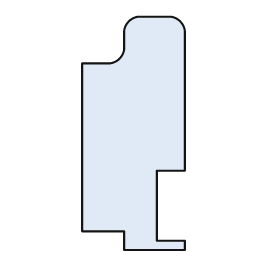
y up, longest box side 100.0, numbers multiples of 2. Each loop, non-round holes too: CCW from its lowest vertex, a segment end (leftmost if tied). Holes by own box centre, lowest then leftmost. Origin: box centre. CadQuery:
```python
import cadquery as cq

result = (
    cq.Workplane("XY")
    .moveTo(-4.0, -50.0)
    .lineTo(22.0, -50.0)
    .lineTo(22.0, -46.0)
    .lineTo(10.0, -46.0)
    .lineTo(10.0, -16.0)
    .lineTo(22.0, -16.0)
    .lineTo(22.0, 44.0)
    .threePointArc((20.0, 48.0), (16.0, 50.0))
    .lineTo(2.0, 50.0)
    .threePointArc((-2.0, 48.0), (-4.0, 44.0))
    .lineTo(-4.0, 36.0)
    .threePointArc((-6.0, 32.0), (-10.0, 30.0))
    .lineTo(-22.0, 30.0)
    .lineTo(-22.0, -42.0)
    .lineTo(-4.0, -42.0)
    .close()
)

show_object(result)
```